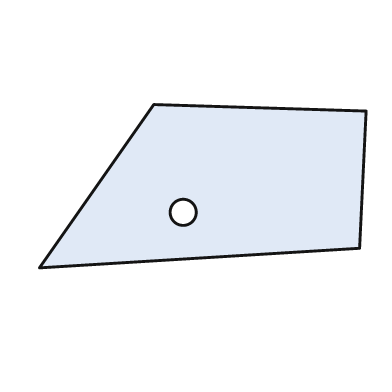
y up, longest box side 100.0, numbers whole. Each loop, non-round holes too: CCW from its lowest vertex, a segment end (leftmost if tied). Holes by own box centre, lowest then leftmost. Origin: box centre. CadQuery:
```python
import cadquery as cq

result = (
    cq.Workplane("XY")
    .moveTo(-50.0, -25.0)
    .lineTo(48.0, -19.0)
    .lineTo(50.0, 23.0)
    .lineTo(-15.0, 25.0)
    .close()
    .moveTo(-6.0, -8.0)
    .circle(4.0)
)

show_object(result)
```